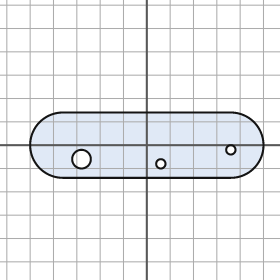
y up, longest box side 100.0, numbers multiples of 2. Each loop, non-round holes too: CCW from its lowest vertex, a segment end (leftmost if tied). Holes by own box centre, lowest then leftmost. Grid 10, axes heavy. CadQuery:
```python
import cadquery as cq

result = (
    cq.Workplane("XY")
    .moveTo(-36.0, -14.0)
    .lineTo(36.0, -14.0)
    .threePointArc((50.0, 0.0), (36.0, 14.0))
    .lineTo(-36.0, 14.0)
    .threePointArc((-50.0, 0.0), (-36.0, -14.0))
    .close()
    .moveTo(6.0, -8.0)
    .circle(2.0)
    .moveTo(-28.0, -6.0)
    .circle(4.0)
    .moveTo(36.0, -2.0)
    .circle(2.0)
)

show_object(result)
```